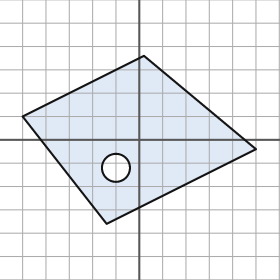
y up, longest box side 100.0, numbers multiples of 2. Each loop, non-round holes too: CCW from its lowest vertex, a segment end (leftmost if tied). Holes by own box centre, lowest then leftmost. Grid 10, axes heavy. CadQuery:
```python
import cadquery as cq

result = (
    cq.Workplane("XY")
    .moveTo(-14.0, -36.0)
    .lineTo(50.0, -4.0)
    .lineTo(2.0, 36.0)
    .lineTo(-50.0, 10.0)
    .close()
    .moveTo(-10.0, -12.0)
    .circle(6.0)
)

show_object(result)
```